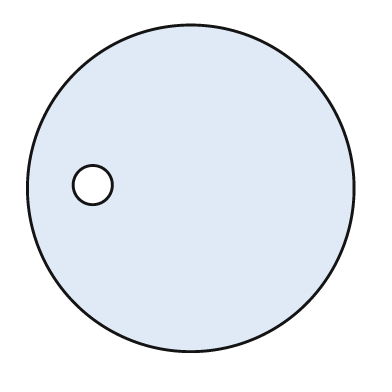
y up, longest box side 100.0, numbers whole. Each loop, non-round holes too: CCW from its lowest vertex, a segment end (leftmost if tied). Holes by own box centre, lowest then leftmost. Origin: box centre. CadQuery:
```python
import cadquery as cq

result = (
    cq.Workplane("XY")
    .moveTo(0.0, 0.0)
    .circle(50.0)
    .moveTo(-30.0, 1.0)
    .circle(6.0)
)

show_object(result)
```